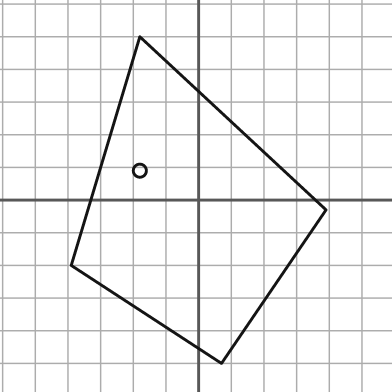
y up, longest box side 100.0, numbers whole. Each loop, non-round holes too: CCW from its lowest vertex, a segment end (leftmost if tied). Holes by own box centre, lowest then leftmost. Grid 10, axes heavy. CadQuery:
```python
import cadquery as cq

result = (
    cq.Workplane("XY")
    .moveTo(7.0, -50.0)
    .lineTo(39.0, -3.0)
    .lineTo(-18.0, 50.0)
    .lineTo(-39.0, -20.0)
    .close()
    .moveTo(-18.0, 9.0)
    .circle(2.0)
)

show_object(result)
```